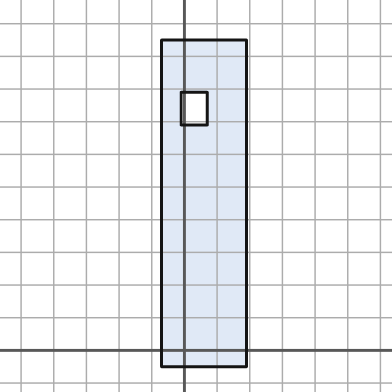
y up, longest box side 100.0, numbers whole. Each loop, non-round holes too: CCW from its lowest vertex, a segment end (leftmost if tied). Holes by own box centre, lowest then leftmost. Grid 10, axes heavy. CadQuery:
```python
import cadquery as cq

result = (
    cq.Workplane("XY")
    .moveTo(-7.0, -5.0)
    .lineTo(19.0, -5.0)
    .lineTo(19.0, 95.0)
    .lineTo(-7.0, 95.0)
    .close()
    .moveTo(-1.0, 69.0)
    .lineTo(7.0, 69.0)
    .lineTo(7.0, 79.0)
    .lineTo(-1.0, 79.0)
    .close()
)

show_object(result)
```